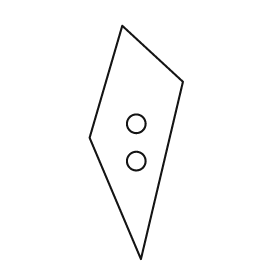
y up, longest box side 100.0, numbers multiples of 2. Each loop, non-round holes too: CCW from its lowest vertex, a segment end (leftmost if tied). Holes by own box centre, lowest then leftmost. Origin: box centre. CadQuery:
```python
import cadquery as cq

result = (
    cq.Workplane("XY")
    .moveTo(2.0, -50.0)
    .lineTo(20.0, 26.0)
    .lineTo(-6.0, 50.0)
    .lineTo(-20.0, 2.0)
    .close()
    .moveTo(0.0, -8.0)
    .circle(4.0)
    .moveTo(0.0, 8.0)
    .circle(4.0)
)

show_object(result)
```